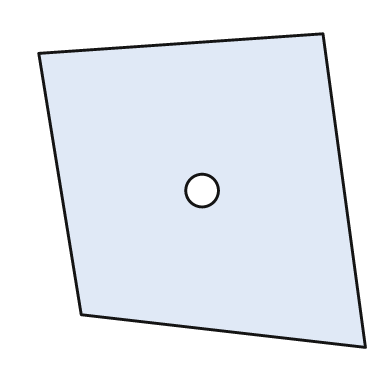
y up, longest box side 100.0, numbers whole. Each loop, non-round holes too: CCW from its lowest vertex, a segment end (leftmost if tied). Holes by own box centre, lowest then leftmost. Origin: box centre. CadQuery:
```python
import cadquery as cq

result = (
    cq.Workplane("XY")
    .moveTo(50.0, -48.0)
    .lineTo(37.0, 48.0)
    .lineTo(-50.0, 42.0)
    .lineTo(-37.0, -38.0)
    .close()
    .moveTo(0.0, 0.0)
    .circle(5.0)
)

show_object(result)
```